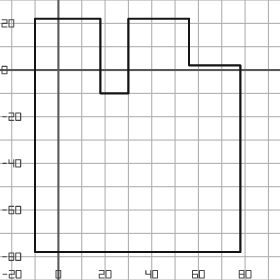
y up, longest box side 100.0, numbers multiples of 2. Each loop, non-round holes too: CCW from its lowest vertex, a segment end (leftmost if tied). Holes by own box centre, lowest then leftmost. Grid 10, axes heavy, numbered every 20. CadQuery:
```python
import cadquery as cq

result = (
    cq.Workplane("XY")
    .moveTo(-10.0, -78.0)
    .lineTo(78.0, -78.0)
    .lineTo(78.0, 2.0)
    .lineTo(56.0, 2.0)
    .lineTo(56.0, 22.0)
    .lineTo(30.0, 22.0)
    .lineTo(30.0, -10.0)
    .lineTo(18.0, -10.0)
    .lineTo(18.0, 22.0)
    .lineTo(-10.0, 22.0)
    .close()
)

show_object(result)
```